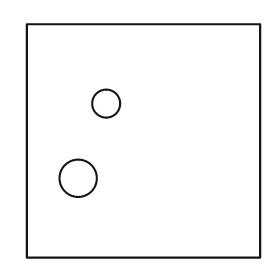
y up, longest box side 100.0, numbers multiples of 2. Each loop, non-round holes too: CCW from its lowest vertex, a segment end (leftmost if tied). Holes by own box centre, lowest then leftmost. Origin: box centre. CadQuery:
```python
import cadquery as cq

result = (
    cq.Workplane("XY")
    .moveTo(-50.0, -50.0)
    .lineTo(50.0, -50.0)
    .lineTo(50.0, 50.0)
    .lineTo(-50.0, 50.0)
    .close()
    .moveTo(-28.0, -16.0)
    .circle(8.0)
    .moveTo(-16.0, 16.0)
    .circle(6.0)
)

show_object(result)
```